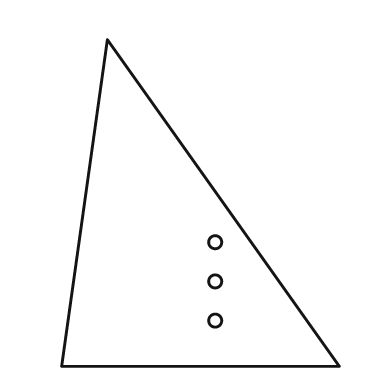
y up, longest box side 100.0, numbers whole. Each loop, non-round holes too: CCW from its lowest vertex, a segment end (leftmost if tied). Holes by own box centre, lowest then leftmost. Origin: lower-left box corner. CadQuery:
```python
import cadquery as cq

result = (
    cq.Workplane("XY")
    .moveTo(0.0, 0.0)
    .lineTo(85.0, 0.0)
    .lineTo(14.0, 100.0)
    .close()
    .moveTo(47.0, 14.0)
    .circle(2.0)
    .moveTo(47.0, 26.0)
    .circle(2.0)
    .moveTo(47.0, 38.0)
    .circle(2.0)
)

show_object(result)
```